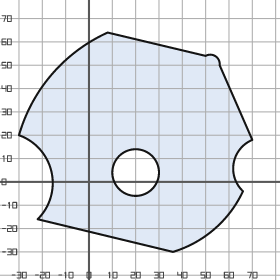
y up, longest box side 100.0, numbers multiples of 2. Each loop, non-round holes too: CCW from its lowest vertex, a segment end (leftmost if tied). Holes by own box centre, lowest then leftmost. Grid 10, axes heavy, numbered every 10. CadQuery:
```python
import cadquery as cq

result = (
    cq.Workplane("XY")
    .moveTo(36.0, -30.0)
    .threePointArc((54.0, -20.0), (66.0, -4.0))
    .threePointArc((62.0, 8.0), (70.0, 18.0))
    .lineTo(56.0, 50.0)
    .threePointArc((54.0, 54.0), (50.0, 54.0))
    .lineTo(8.0, 64.0)
    .threePointArc((-16.0, 46.0), (-30.0, 20.0))
    .threePointArc((-16.0, 4.0), (-22.0, -16.0))
    .close()
    .moveTo(20.0, 4.0)
    .circle(10.0)
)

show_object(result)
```